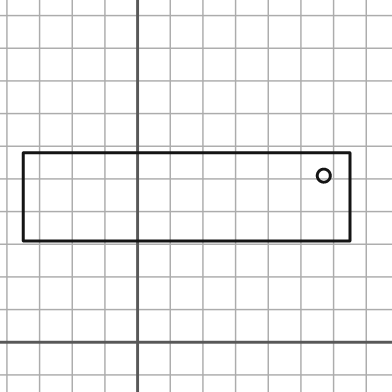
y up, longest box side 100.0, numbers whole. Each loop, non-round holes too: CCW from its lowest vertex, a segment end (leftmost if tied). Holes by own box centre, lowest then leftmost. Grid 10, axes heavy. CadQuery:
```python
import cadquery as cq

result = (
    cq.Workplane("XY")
    .moveTo(-35.0, 31.0)
    .lineTo(65.0, 31.0)
    .lineTo(65.0, 58.0)
    .lineTo(-35.0, 58.0)
    .close()
    .moveTo(57.0, 51.0)
    .circle(2.0)
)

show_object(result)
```